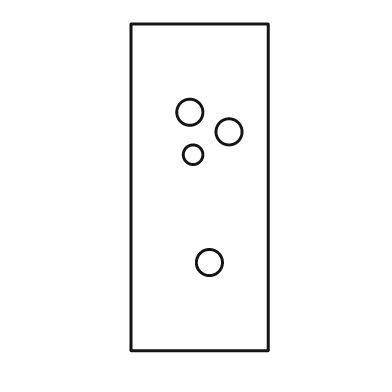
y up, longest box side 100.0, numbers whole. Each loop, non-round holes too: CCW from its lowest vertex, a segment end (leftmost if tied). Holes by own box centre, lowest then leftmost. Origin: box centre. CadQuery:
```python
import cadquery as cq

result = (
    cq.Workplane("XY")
    .moveTo(-21.0, -50.0)
    .lineTo(21.0, -50.0)
    .lineTo(21.0, 50.0)
    .lineTo(-21.0, 50.0)
    .close()
    .moveTo(3.0, -23.0)
    .circle(4.0)
    .moveTo(-2.0, 10.0)
    .circle(3.0)
    .moveTo(9.0, 17.0)
    .circle(4.0)
    .moveTo(-3.0, 23.0)
    .circle(4.0)
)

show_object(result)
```